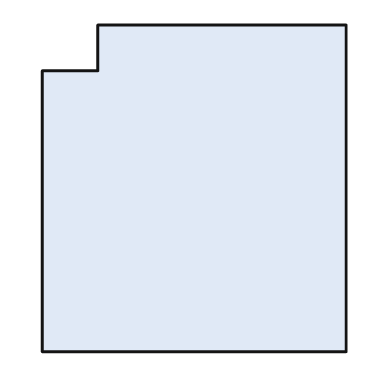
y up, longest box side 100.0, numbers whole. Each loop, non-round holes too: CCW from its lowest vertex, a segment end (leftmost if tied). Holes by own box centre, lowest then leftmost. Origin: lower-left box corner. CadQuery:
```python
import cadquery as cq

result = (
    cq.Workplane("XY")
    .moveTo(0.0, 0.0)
    .lineTo(93.0, 0.0)
    .lineTo(93.0, 100.0)
    .lineTo(17.0, 100.0)
    .lineTo(17.0, 86.0)
    .lineTo(0.0, 86.0)
    .close()
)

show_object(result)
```